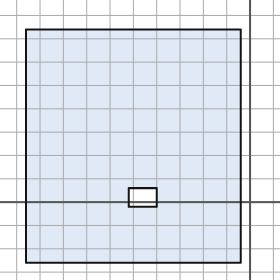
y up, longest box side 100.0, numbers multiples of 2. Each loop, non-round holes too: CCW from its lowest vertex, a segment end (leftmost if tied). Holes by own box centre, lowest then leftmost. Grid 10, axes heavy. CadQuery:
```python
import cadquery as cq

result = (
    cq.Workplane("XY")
    .moveTo(-96.0, -26.0)
    .lineTo(-4.0, -26.0)
    .lineTo(-4.0, 74.0)
    .lineTo(-96.0, 74.0)
    .close()
    .moveTo(-52.0, -2.0)
    .lineTo(-40.0, -2.0)
    .lineTo(-40.0, 6.0)
    .lineTo(-52.0, 6.0)
    .close()
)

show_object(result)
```